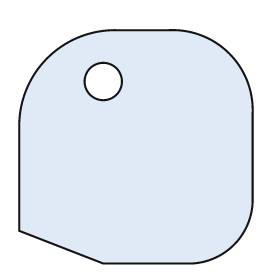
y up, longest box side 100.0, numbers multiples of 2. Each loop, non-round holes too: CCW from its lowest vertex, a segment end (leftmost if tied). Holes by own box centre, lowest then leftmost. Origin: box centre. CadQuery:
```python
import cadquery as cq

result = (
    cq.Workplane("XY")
    .moveTo(-14.0, -50.0)
    .lineTo(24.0, -50.0)
    .threePointArc((42.0, -42.0), (50.0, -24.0))
    .lineTo(50.0, 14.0)
    .threePointArc((40.0, 40.0), (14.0, 50.0))
    .lineTo(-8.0, 50.0)
    .threePointArc((-38.0, 38.0), (-50.0, 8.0))
    .lineTo(-50.0, -36.0)
    .close()
    .moveTo(-14.0, 28.0)
    .circle(8.0)
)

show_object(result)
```